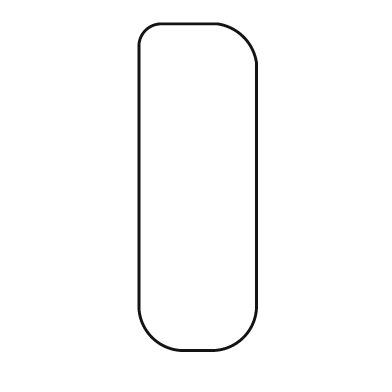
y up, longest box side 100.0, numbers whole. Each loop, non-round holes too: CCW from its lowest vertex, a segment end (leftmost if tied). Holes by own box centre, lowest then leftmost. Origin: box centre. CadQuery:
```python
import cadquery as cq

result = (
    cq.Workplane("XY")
    .moveTo(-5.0, -50.0)
    .lineTo(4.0, -50.0)
    .threePointArc((14.0, -46.0), (18.0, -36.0))
    .lineTo(18.0, 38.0)
    .threePointArc((14.0, 46.0), (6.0, 50.0))
    .lineTo(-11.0, 50.0)
    .threePointArc((-16.0, 48.0), (-18.0, 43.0))
    .lineTo(-18.0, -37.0)
    .threePointArc((-14.0, -46.0), (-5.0, -50.0))
    .close()
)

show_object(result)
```